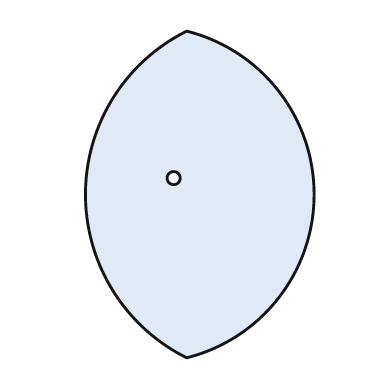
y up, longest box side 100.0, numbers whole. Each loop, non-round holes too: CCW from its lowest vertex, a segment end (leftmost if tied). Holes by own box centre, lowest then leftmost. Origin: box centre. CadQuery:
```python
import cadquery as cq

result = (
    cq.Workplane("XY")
    .moveTo(-4.0, -50.0)
    .threePointArc((35.0, 0.0), (-4.0, 50.0))
    .threePointArc((-35.0, 0.0), (-4.0, -50.0))
    .close()
    .moveTo(-8.0, 5.0)
    .circle(2.0)
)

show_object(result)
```